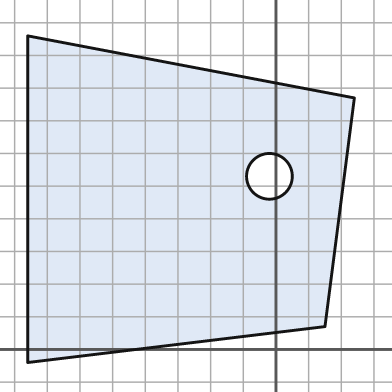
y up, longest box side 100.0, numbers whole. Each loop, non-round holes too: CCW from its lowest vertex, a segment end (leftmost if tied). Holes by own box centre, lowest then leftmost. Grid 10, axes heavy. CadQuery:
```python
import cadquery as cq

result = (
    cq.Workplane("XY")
    .moveTo(-76.0, -4.0)
    .lineTo(15.0, 7.0)
    .lineTo(24.0, 77.0)
    .lineTo(-76.0, 96.0)
    .close()
    .moveTo(-2.0, 53.0)
    .circle(7.0)
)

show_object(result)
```